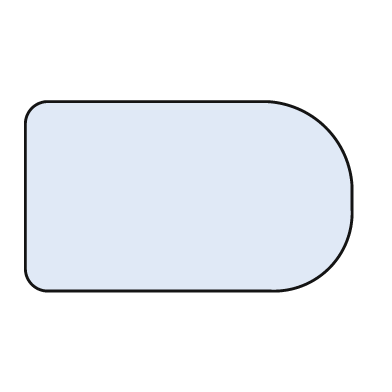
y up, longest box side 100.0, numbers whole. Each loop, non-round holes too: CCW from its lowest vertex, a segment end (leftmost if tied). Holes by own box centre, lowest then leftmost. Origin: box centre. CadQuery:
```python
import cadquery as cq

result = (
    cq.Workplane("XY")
    .moveTo(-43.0, -29.0)
    .lineTo(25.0, -29.0)
    .threePointArc((43.0, -22.0), (50.0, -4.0))
    .lineTo(50.0, 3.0)
    .threePointArc((42.0, 21.0), (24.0, 29.0))
    .lineTo(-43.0, 29.0)
    .threePointArc((-48.0, 27.0), (-50.0, 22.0))
    .lineTo(-50.0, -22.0)
    .threePointArc((-48.0, -27.0), (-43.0, -29.0))
    .close()
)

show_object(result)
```